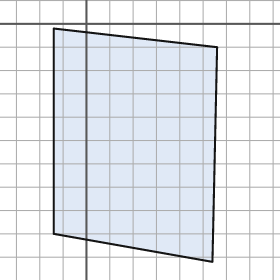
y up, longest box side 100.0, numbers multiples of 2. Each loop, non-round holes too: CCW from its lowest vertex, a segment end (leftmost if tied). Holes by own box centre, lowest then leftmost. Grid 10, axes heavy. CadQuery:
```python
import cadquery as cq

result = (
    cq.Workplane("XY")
    .moveTo(54.0, -102.0)
    .lineTo(56.0, -10.0)
    .lineTo(-14.0, -2.0)
    .lineTo(-14.0, -90.0)
    .close()
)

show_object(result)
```